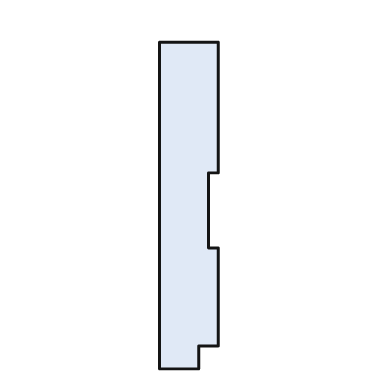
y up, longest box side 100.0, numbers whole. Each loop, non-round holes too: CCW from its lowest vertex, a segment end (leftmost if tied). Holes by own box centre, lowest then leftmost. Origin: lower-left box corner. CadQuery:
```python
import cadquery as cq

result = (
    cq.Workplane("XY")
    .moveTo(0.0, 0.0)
    .lineTo(12.0, 0.0)
    .lineTo(12.0, 7.0)
    .lineTo(18.0, 7.0)
    .lineTo(18.0, 37.0)
    .lineTo(15.0, 37.0)
    .lineTo(15.0, 60.0)
    .lineTo(18.0, 60.0)
    .lineTo(18.0, 100.0)
    .lineTo(0.0, 100.0)
    .close()
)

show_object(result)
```